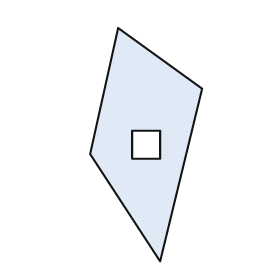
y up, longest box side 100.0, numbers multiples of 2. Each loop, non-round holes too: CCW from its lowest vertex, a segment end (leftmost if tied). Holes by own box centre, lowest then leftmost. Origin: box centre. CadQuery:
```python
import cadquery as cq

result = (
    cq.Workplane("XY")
    .moveTo(6.0, -50.0)
    .lineTo(24.0, 24.0)
    .lineTo(-12.0, 50.0)
    .lineTo(-24.0, -4.0)
    .close()
    .moveTo(-6.0, -6.0)
    .lineTo(6.0, -6.0)
    .lineTo(6.0, 6.0)
    .lineTo(-6.0, 6.0)
    .close()
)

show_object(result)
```